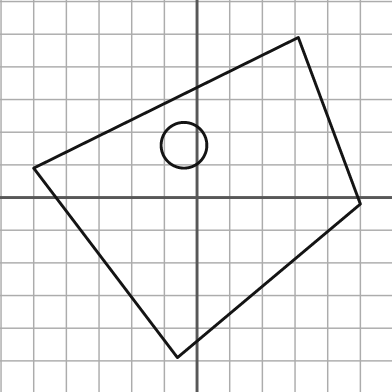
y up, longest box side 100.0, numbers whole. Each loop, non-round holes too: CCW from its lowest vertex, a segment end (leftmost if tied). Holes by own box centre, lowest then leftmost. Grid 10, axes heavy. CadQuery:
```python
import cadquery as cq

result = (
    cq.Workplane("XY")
    .moveTo(-6.0, -49.0)
    .lineTo(50.0, -2.0)
    .lineTo(31.0, 49.0)
    .lineTo(-50.0, 9.0)
    .close()
    .moveTo(-4.0, 16.0)
    .circle(7.0)
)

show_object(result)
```